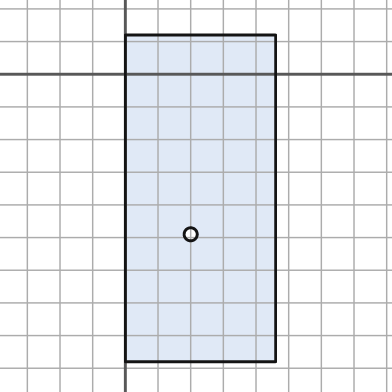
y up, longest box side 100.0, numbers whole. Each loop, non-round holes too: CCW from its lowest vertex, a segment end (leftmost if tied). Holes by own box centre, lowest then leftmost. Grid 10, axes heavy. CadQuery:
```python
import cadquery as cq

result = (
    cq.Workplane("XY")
    .moveTo(0.0, -88.0)
    .lineTo(46.0, -88.0)
    .lineTo(46.0, 12.0)
    .lineTo(0.0, 12.0)
    .close()
    .moveTo(20.0, -49.0)
    .circle(2.0)
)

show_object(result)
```